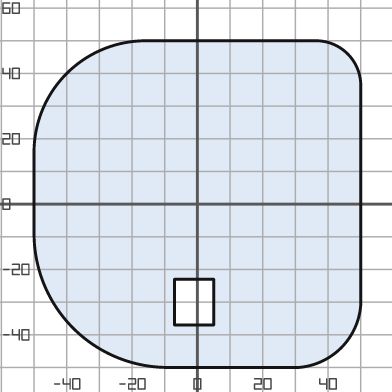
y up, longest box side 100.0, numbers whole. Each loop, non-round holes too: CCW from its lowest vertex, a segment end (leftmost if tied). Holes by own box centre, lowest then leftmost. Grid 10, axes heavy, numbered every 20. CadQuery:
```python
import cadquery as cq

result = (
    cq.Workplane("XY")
    .moveTo(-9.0, -50.0)
    .lineTo(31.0, -50.0)
    .threePointArc((44.0, -44.0), (50.0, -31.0))
    .lineTo(50.0, 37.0)
    .threePointArc((46.0, 46.0), (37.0, 50.0))
    .lineTo(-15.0, 50.0)
    .threePointArc((-40.0, 40.0), (-50.0, 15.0))
    .lineTo(-50.0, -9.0)
    .threePointArc((-38.0, -38.0), (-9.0, -50.0))
    .close()
    .moveTo(-7.0, -37.0)
    .lineTo(5.0, -37.0)
    .lineTo(5.0, -23.0)
    .lineTo(-7.0, -23.0)
    .close()
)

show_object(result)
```